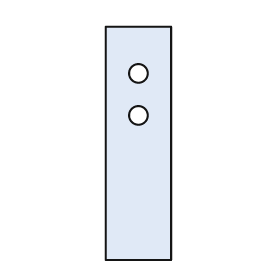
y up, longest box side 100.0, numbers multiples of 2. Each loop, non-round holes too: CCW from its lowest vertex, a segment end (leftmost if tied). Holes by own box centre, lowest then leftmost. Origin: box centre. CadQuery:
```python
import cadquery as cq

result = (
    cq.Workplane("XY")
    .moveTo(-14.0, -50.0)
    .lineTo(14.0, -50.0)
    .lineTo(14.0, 50.0)
    .lineTo(-14.0, 50.0)
    .close()
    .moveTo(0.0, 12.0)
    .circle(4.0)
    .moveTo(0.0, 30.0)
    .circle(4.0)
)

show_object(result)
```